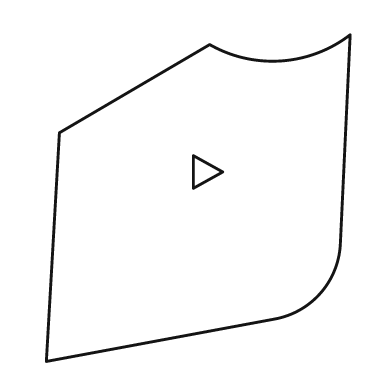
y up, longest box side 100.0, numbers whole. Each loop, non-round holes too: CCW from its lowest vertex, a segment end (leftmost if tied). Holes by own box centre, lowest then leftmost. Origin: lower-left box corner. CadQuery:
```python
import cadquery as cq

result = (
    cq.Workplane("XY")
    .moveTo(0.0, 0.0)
    .lineTo(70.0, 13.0)
    .threePointArc((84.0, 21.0), (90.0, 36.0))
    .lineTo(93.0, 100.0)
    .threePointArc((72.0, 92.0), (50.0, 97.0))
    .lineTo(4.0, 70.0)
    .close()
    .moveTo(45.0, 53.0)
    .lineTo(54.0, 58.0)
    .lineTo(45.0, 63.0)
    .close()
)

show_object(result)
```